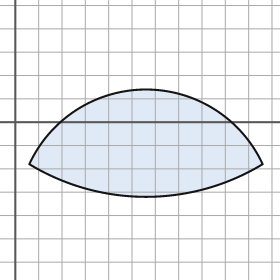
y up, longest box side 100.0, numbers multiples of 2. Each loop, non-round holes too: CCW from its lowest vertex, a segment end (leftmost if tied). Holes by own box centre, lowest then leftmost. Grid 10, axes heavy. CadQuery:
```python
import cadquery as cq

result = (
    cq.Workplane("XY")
    .moveTo(6.0, -18.0)
    .threePointArc((56.0, -32.0), (106.0, -18.0))
    .threePointArc((56.0, 14.0), (6.0, -18.0))
    .close()
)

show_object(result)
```